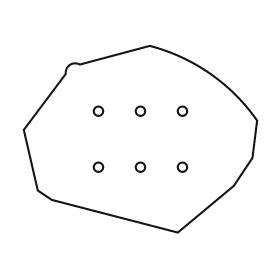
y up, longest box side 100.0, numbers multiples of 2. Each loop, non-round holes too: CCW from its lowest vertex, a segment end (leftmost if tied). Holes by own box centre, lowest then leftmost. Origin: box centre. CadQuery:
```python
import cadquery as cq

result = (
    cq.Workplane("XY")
    .moveTo(16.0, -40.0)
    .lineTo(40.0, -20.0)
    .lineTo(48.0, -8.0)
    .lineTo(50.0, 8.0)
    .threePointArc((30.0, 28.0), (4.0, 40.0))
    .lineTo(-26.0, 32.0)
    .threePointArc((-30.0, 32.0), (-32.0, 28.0))
    .lineTo(-50.0, 4.0)
    .lineTo(-44.0, -22.0)
    .lineTo(-38.0, -26.0)
    .close()
    .moveTo(-18.0, -12.0)
    .circle(2.0)
    .moveTo(0.0, -12.0)
    .circle(2.0)
    .moveTo(18.0, -12.0)
    .circle(2.0)
    .moveTo(-18.0, 12.0)
    .circle(2.0)
    .moveTo(0.0, 12.0)
    .circle(2.0)
    .moveTo(18.0, 12.0)
    .circle(2.0)
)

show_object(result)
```